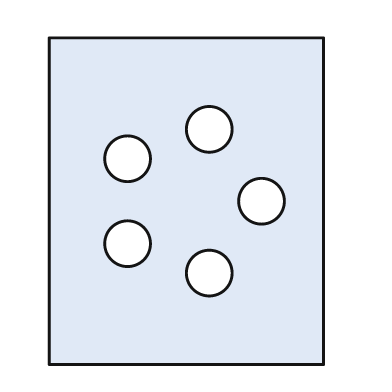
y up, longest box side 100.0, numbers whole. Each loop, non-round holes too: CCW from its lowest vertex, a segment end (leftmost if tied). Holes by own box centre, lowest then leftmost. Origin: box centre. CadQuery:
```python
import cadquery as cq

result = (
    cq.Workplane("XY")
    .moveTo(-42.0, -50.0)
    .lineTo(42.0, -50.0)
    .lineTo(42.0, 50.0)
    .lineTo(-42.0, 50.0)
    .close()
    .moveTo(7.0, -22.0)
    .circle(7.0)
    .moveTo(-18.0, -13.0)
    .circle(7.0)
    .moveTo(23.0, 0.0)
    .circle(7.0)
    .moveTo(-18.0, 13.0)
    .circle(7.0)
    .moveTo(7.0, 22.0)
    .circle(7.0)
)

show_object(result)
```